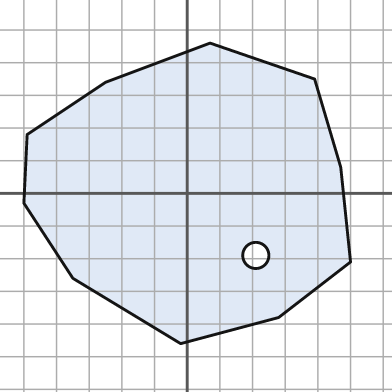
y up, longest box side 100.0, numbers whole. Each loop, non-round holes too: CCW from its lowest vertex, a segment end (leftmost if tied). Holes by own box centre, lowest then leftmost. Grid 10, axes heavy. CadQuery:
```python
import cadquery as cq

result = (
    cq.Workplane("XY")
    .moveTo(-2.0, -46.0)
    .lineTo(28.0, -38.0)
    .lineTo(50.0, -21.0)
    .lineTo(47.0, 8.0)
    .lineTo(39.0, 35.0)
    .lineTo(7.0, 46.0)
    .lineTo(-25.0, 34.0)
    .lineTo(-49.0, 18.0)
    .lineTo(-50.0, -3.0)
    .lineTo(-35.0, -26.0)
    .close()
    .moveTo(21.0, -19.0)
    .circle(4.0)
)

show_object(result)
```